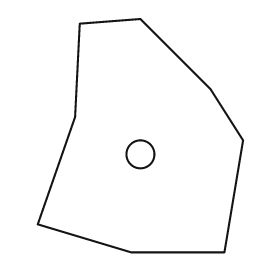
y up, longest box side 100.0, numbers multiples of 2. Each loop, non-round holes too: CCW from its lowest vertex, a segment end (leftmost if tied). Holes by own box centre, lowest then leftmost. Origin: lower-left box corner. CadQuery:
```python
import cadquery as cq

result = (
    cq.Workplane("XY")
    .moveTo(40.0, 0.0)
    .lineTo(80.0, 0.0)
    .lineTo(88.0, 48.0)
    .lineTo(74.0, 70.0)
    .lineTo(44.0, 100.0)
    .lineTo(18.0, 98.0)
    .lineTo(16.0, 58.0)
    .lineTo(0.0, 12.0)
    .close()
    .moveTo(44.0, 42.0)
    .circle(6.0)
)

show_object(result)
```